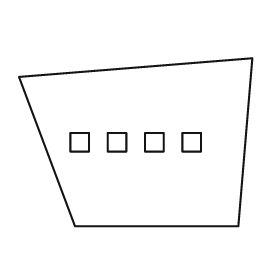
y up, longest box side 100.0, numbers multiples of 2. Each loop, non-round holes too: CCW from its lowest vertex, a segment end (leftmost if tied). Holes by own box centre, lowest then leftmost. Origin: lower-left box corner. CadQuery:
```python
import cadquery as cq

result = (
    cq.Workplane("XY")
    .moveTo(24.0, 0.0)
    .lineTo(94.0, 0.0)
    .lineTo(100.0, 72.0)
    .lineTo(0.0, 64.0)
    .close()
    .moveTo(22.0, 32.0)
    .lineTo(30.0, 32.0)
    .lineTo(30.0, 40.0)
    .lineTo(22.0, 40.0)
    .close()
    .moveTo(38.0, 32.0)
    .lineTo(46.0, 32.0)
    .lineTo(46.0, 40.0)
    .lineTo(38.0, 40.0)
    .close()
    .moveTo(54.0, 32.0)
    .lineTo(62.0, 32.0)
    .lineTo(62.0, 40.0)
    .lineTo(54.0, 40.0)
    .close()
    .moveTo(70.0, 32.0)
    .lineTo(78.0, 32.0)
    .lineTo(78.0, 40.0)
    .lineTo(70.0, 40.0)
    .close()
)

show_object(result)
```